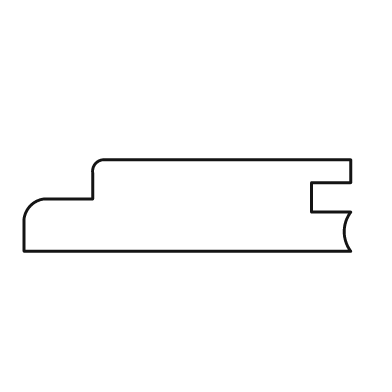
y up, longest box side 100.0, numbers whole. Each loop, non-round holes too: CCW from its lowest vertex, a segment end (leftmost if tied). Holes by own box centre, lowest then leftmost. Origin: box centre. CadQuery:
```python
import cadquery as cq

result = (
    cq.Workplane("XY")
    .moveTo(-50.0, -14.0)
    .lineTo(50.0, -14.0)
    .threePointArc((48.0, -8.0), (50.0, -2.0))
    .lineTo(38.0, -2.0)
    .lineTo(38.0, 7.0)
    .lineTo(50.0, 7.0)
    .lineTo(50.0, 14.0)
    .lineTo(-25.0, 14.0)
    .threePointArc((-28.0, 13.0), (-29.0, 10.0))
    .lineTo(-29.0, 2.0)
    .lineTo(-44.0, 2.0)
    .threePointArc((-48.0, 0.0), (-50.0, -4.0))
    .close()
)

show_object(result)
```